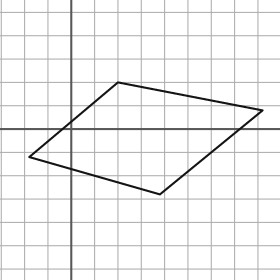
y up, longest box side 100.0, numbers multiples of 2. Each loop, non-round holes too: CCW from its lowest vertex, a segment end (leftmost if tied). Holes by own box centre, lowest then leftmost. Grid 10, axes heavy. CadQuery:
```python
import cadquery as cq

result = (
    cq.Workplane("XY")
    .moveTo(38.0, -28.0)
    .lineTo(82.0, 8.0)
    .lineTo(20.0, 20.0)
    .lineTo(-18.0, -12.0)
    .close()
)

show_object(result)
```